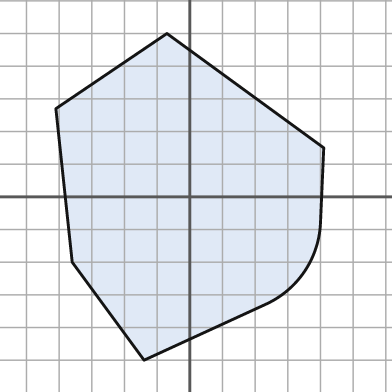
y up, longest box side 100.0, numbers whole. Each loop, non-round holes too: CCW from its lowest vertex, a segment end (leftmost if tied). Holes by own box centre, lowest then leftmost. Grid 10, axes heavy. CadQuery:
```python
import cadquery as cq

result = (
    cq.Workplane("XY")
    .moveTo(-14.0, -50.0)
    .lineTo(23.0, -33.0)
    .threePointArc((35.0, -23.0), (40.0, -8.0))
    .lineTo(41.0, 15.0)
    .lineTo(-7.0, 50.0)
    .lineTo(-41.0, 27.0)
    .lineTo(-36.0, -20.0)
    .close()
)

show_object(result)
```